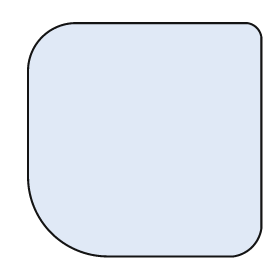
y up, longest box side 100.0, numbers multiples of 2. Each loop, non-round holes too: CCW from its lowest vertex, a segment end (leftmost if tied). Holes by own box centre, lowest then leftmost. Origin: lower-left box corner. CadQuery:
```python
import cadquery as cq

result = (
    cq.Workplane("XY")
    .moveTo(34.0, 0.0)
    .lineTo(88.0, 0.0)
    .threePointArc((96.0, 4.0), (100.0, 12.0))
    .lineTo(100.0, 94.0)
    .threePointArc((98.0, 98.0), (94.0, 100.0))
    .lineTo(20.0, 100.0)
    .threePointArc((6.0, 94.0), (0.0, 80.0))
    .lineTo(0.0, 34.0)
    .threePointArc((10.0, 10.0), (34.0, 0.0))
    .close()
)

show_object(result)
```